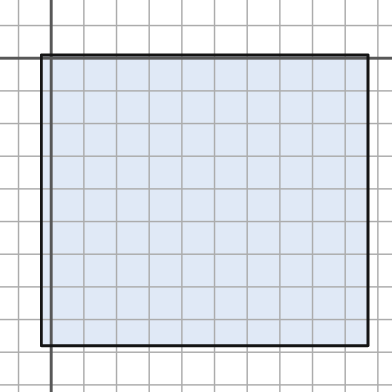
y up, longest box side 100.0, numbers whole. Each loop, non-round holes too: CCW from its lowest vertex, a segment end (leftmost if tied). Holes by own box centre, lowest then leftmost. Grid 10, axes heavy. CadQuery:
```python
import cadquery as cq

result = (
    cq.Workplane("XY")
    .moveTo(-3.0, -88.0)
    .lineTo(97.0, -88.0)
    .lineTo(97.0, 1.0)
    .lineTo(-3.0, 1.0)
    .close()
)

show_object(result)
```